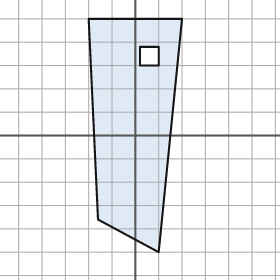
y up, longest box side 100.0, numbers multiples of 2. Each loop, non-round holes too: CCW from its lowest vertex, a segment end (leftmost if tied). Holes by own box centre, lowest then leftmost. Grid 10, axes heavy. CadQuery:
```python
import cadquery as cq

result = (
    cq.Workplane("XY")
    .moveTo(10.0, -50.0)
    .lineTo(20.0, 50.0)
    .lineTo(-20.0, 50.0)
    .lineTo(-16.0, -36.0)
    .close()
    .moveTo(2.0, 30.0)
    .lineTo(10.0, 30.0)
    .lineTo(10.0, 38.0)
    .lineTo(2.0, 38.0)
    .close()
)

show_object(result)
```